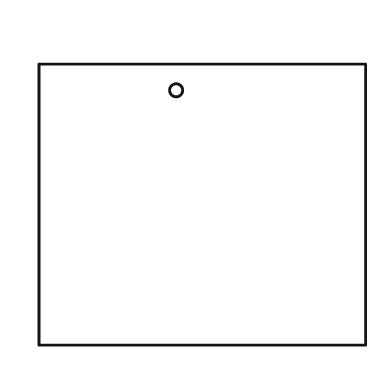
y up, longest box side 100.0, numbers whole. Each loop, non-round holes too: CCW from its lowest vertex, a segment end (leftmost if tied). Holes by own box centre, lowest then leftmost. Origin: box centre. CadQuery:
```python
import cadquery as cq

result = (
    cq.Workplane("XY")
    .moveTo(-50.0, -43.0)
    .lineTo(50.0, -43.0)
    .lineTo(50.0, 43.0)
    .lineTo(-50.0, 43.0)
    .close()
    .moveTo(-8.0, 35.0)
    .circle(2.0)
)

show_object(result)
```